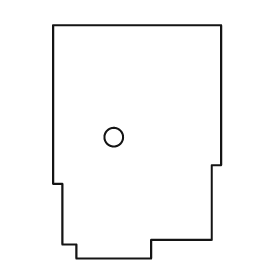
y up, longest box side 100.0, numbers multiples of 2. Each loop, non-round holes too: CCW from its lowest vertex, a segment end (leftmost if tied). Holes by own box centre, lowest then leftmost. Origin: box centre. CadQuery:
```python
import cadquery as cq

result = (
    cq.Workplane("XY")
    .moveTo(-26.0, -50.0)
    .lineTo(6.0, -50.0)
    .lineTo(6.0, -42.0)
    .lineTo(32.0, -42.0)
    .lineTo(32.0, -10.0)
    .lineTo(36.0, -10.0)
    .lineTo(36.0, 50.0)
    .lineTo(-36.0, 50.0)
    .lineTo(-36.0, -18.0)
    .lineTo(-32.0, -18.0)
    .lineTo(-32.0, -44.0)
    .lineTo(-26.0, -44.0)
    .close()
    .moveTo(-10.0, 2.0)
    .circle(4.0)
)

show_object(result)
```